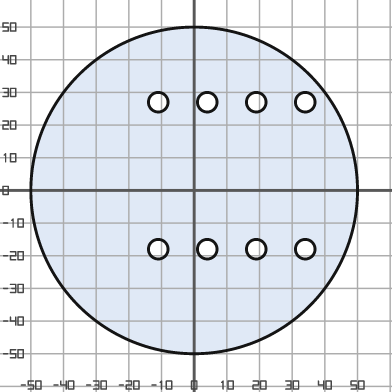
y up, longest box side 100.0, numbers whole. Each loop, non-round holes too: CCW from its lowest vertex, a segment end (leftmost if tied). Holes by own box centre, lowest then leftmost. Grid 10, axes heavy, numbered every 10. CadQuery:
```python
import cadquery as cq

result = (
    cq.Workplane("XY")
    .moveTo(0.0, 0.0)
    .circle(50.0)
    .moveTo(-11.0, -18.0)
    .circle(3.0)
    .moveTo(4.0, -18.0)
    .circle(3.0)
    .moveTo(19.0, -18.0)
    .circle(3.0)
    .moveTo(34.0, -18.0)
    .circle(3.0)
    .moveTo(-11.0, 27.0)
    .circle(3.0)
    .moveTo(4.0, 27.0)
    .circle(3.0)
    .moveTo(19.0, 27.0)
    .circle(3.0)
    .moveTo(34.0, 27.0)
    .circle(3.0)
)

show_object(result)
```